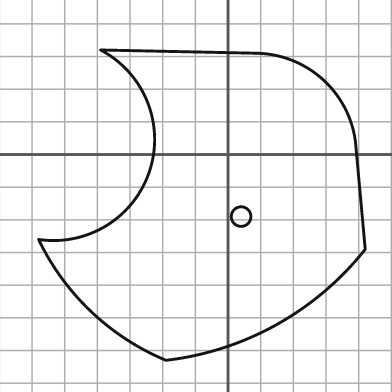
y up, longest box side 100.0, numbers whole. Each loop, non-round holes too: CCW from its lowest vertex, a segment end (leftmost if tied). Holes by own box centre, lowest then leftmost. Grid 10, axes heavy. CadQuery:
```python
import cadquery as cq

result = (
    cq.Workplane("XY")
    .moveTo(-19.0, -63.0)
    .threePointArc((15.0, -52.0), (42.0, -29.0))
    .lineTo(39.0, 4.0)
    .threePointArc((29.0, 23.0), (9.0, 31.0))
    .lineTo(-39.0, 32.0)
    .threePointArc((-24.0, -5.0), (-58.0, -26.0))
    .threePointArc((-42.0, -48.0), (-19.0, -63.0))
    .close()
    .moveTo(4.0, -19.0)
    .circle(3.0)
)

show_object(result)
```